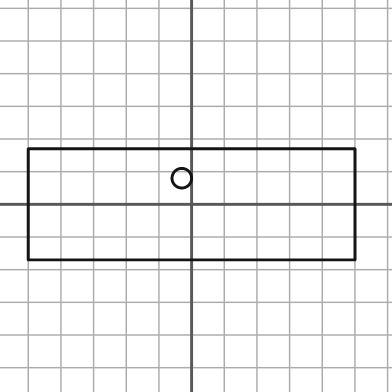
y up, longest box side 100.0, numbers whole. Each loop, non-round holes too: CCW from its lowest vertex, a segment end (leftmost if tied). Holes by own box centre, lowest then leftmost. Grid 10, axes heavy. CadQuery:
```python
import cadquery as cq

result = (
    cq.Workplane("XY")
    .moveTo(-50.0, -17.0)
    .lineTo(50.0, -17.0)
    .lineTo(50.0, 17.0)
    .lineTo(-50.0, 17.0)
    .close()
    .moveTo(-3.0, 8.0)
    .circle(3.0)
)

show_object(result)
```